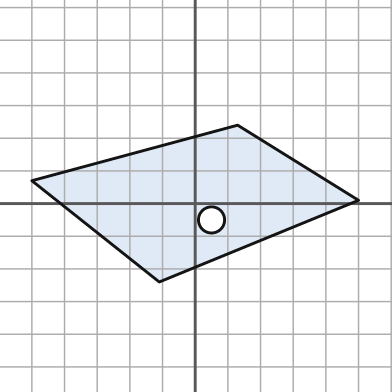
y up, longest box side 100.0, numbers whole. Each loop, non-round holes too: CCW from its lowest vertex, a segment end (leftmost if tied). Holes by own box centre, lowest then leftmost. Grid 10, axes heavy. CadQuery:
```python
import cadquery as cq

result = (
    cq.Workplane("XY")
    .moveTo(-11.0, -24.0)
    .lineTo(50.0, 1.0)
    .lineTo(13.0, 24.0)
    .lineTo(-50.0, 7.0)
    .close()
    .moveTo(5.0, -5.0)
    .circle(4.0)
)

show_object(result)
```